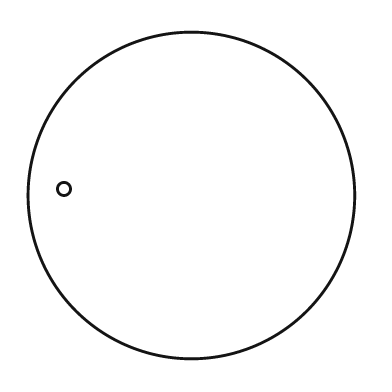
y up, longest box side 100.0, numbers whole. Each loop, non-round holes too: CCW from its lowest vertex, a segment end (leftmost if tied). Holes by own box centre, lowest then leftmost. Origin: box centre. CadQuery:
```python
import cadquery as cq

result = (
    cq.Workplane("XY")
    .moveTo(0.0, 0.0)
    .circle(50.0)
    .moveTo(-39.0, 2.0)
    .circle(2.0)
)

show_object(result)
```